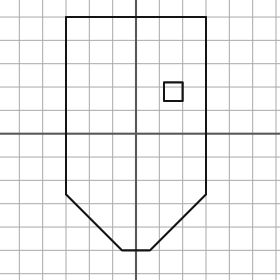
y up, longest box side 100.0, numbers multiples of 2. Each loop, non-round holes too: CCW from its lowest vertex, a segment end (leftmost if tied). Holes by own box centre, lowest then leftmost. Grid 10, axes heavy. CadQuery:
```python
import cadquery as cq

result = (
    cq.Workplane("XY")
    .moveTo(-6.0, -50.0)
    .lineTo(6.0, -50.0)
    .lineTo(30.0, -26.0)
    .lineTo(30.0, 50.0)
    .lineTo(-30.0, 50.0)
    .lineTo(-30.0, -26.0)
    .close()
    .moveTo(12.0, 14.0)
    .lineTo(20.0, 14.0)
    .lineTo(20.0, 22.0)
    .lineTo(12.0, 22.0)
    .close()
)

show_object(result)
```